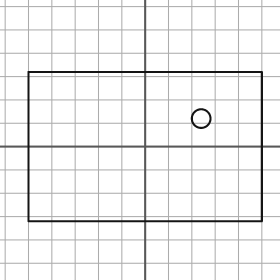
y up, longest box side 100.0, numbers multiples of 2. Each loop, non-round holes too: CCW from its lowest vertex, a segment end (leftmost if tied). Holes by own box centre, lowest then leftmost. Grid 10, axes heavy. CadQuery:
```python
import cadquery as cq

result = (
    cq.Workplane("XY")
    .moveTo(-50.0, -32.0)
    .lineTo(50.0, -32.0)
    .lineTo(50.0, 32.0)
    .lineTo(-50.0, 32.0)
    .close()
    .moveTo(24.0, 12.0)
    .circle(4.0)
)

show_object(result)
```